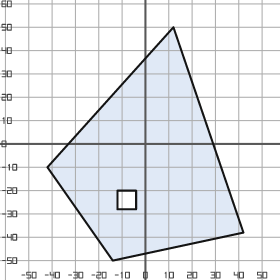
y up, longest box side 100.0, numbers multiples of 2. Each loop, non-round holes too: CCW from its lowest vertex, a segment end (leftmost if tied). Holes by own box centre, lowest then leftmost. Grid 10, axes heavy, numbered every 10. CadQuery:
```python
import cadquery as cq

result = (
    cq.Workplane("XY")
    .moveTo(-14.0, -50.0)
    .lineTo(42.0, -38.0)
    .lineTo(12.0, 50.0)
    .lineTo(-42.0, -10.0)
    .close()
    .moveTo(-12.0, -28.0)
    .lineTo(-4.0, -28.0)
    .lineTo(-4.0, -20.0)
    .lineTo(-12.0, -20.0)
    .close()
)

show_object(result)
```